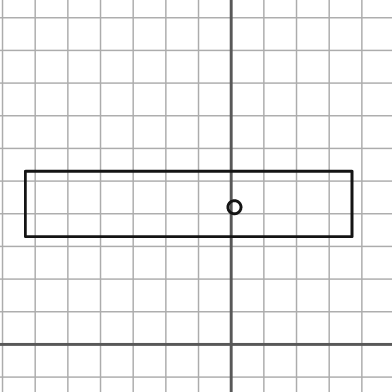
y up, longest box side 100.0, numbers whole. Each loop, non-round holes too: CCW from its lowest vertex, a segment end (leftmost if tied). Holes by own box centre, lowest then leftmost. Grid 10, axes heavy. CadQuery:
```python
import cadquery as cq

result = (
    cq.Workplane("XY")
    .moveTo(-63.0, 33.0)
    .lineTo(37.0, 33.0)
    .lineTo(37.0, 53.0)
    .lineTo(-63.0, 53.0)
    .close()
    .moveTo(1.0, 42.0)
    .circle(2.0)
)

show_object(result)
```